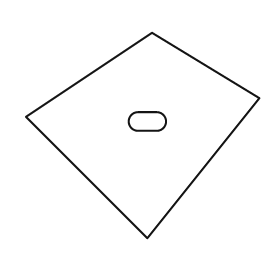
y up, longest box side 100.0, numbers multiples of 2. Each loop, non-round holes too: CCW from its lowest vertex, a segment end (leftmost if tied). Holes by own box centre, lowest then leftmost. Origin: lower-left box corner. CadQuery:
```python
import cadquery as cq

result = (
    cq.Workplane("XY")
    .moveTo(52.0, 0.0)
    .lineTo(100.0, 60.0)
    .lineTo(54.0, 88.0)
    .lineTo(0.0, 52.0)
    .close()
    .moveTo(48.0, 46.0)
    .lineTo(56.0, 46.0)
    .threePointArc((60.0, 50.0), (56.0, 54.0))
    .lineTo(48.0, 54.0)
    .threePointArc((44.0, 50.0), (48.0, 46.0))
    .close()
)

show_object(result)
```